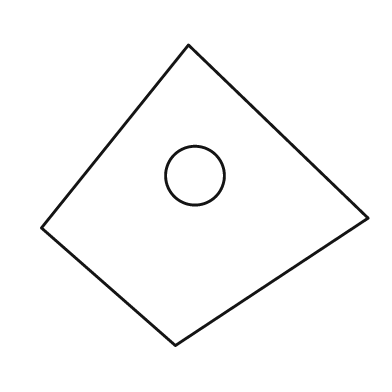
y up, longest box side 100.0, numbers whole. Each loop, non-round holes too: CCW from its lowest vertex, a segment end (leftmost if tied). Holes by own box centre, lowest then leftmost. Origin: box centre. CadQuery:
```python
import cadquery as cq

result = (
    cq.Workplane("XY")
    .moveTo(-9.0, -46.0)
    .lineTo(50.0, -7.0)
    .lineTo(-5.0, 46.0)
    .lineTo(-50.0, -10.0)
    .close()
    .moveTo(-3.0, 6.0)
    .circle(9.0)
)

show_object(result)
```